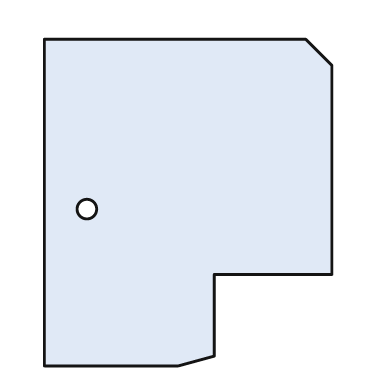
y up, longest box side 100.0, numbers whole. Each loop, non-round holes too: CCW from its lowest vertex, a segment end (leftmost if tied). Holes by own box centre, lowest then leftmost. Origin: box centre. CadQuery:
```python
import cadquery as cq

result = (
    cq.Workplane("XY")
    .moveTo(-44.0, -50.0)
    .lineTo(-3.0, -50.0)
    .lineTo(8.0, -47.0)
    .lineTo(8.0, -22.0)
    .lineTo(44.0, -22.0)
    .lineTo(44.0, 42.0)
    .lineTo(36.0, 50.0)
    .lineTo(-44.0, 50.0)
    .close()
    .moveTo(-31.0, -2.0)
    .circle(3.0)
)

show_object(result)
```